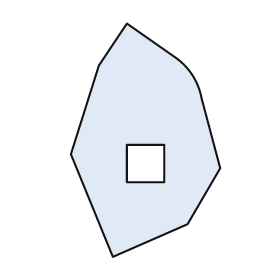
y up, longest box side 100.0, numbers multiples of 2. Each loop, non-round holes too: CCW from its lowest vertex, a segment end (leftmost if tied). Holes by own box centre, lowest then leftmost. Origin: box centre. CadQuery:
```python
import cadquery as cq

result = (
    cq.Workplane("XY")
    .moveTo(-14.0, -50.0)
    .lineTo(18.0, -36.0)
    .lineTo(32.0, -12.0)
    .lineTo(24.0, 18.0)
    .threePointArc((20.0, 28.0), (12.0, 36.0))
    .lineTo(-8.0, 50.0)
    .lineTo(-20.0, 32.0)
    .lineTo(-32.0, -6.0)
    .close()
    .moveTo(-8.0, -18.0)
    .lineTo(8.0, -18.0)
    .lineTo(8.0, -2.0)
    .lineTo(-8.0, -2.0)
    .close()
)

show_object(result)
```